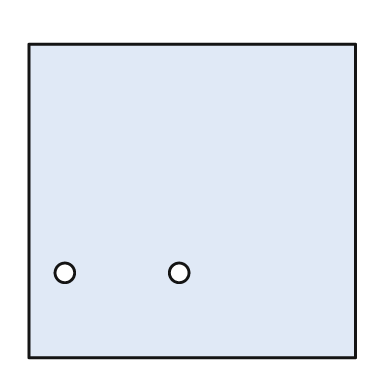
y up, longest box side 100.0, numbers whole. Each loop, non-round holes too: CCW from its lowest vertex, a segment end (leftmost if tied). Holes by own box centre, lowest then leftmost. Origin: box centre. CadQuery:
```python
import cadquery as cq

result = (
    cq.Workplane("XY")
    .moveTo(-50.0, -48.0)
    .lineTo(50.0, -48.0)
    .lineTo(50.0, 48.0)
    .lineTo(-50.0, 48.0)
    .close()
    .moveTo(-39.0, -22.0)
    .circle(3.0)
    .moveTo(-4.0, -22.0)
    .circle(3.0)
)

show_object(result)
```